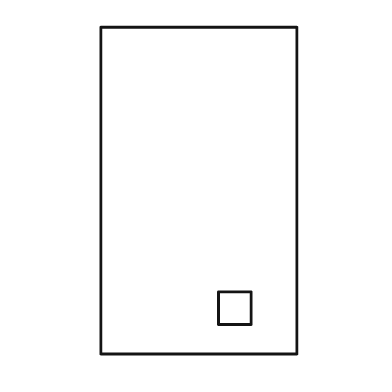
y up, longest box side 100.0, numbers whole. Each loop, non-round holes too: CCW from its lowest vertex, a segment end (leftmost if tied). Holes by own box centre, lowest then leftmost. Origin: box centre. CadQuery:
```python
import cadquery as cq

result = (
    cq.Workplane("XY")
    .moveTo(-30.0, -50.0)
    .lineTo(30.0, -50.0)
    .lineTo(30.0, 50.0)
    .lineTo(-30.0, 50.0)
    .close()
    .moveTo(6.0, -41.0)
    .lineTo(16.0, -41.0)
    .lineTo(16.0, -31.0)
    .lineTo(6.0, -31.0)
    .close()
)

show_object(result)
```